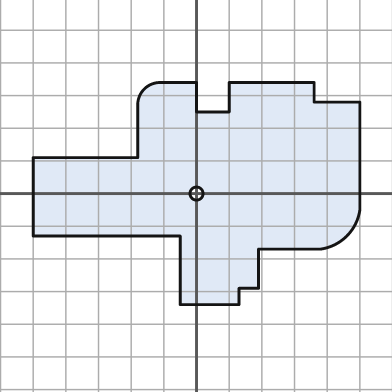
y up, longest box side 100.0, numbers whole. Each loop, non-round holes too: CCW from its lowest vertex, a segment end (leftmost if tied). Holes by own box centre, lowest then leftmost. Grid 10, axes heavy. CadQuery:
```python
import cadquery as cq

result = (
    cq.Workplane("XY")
    .moveTo(-5.0, -34.0)
    .lineTo(13.0, -34.0)
    .lineTo(13.0, -29.0)
    .lineTo(19.0, -29.0)
    .lineTo(19.0, -17.0)
    .lineTo(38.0, -17.0)
    .threePointArc((46.0, -13.0), (50.0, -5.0))
    .lineTo(50.0, 28.0)
    .lineTo(36.0, 28.0)
    .lineTo(36.0, 34.0)
    .lineTo(10.0, 34.0)
    .lineTo(10.0, 25.0)
    .lineTo(0.0, 25.0)
    .lineTo(0.0, 34.0)
    .lineTo(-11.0, 34.0)
    .threePointArc((-16.0, 32.0), (-18.0, 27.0))
    .lineTo(-18.0, 11.0)
    .lineTo(-50.0, 11.0)
    .lineTo(-50.0, -13.0)
    .lineTo(-5.0, -13.0)
    .close()
    .moveTo(0.0, 0.0)
    .circle(2.0)
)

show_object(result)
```